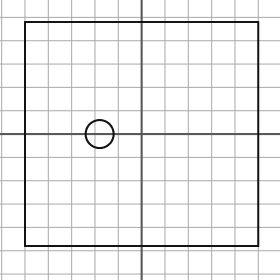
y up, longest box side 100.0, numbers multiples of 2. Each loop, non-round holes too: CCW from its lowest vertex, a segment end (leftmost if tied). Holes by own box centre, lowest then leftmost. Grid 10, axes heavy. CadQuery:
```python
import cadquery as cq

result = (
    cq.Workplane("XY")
    .moveTo(-50.0, -48.0)
    .lineTo(50.0, -48.0)
    .lineTo(50.0, 48.0)
    .lineTo(-50.0, 48.0)
    .close()
    .moveTo(-18.0, 0.0)
    .circle(6.0)
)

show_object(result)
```